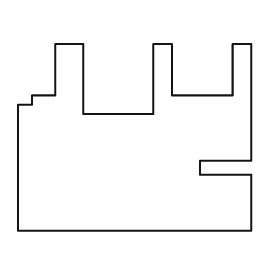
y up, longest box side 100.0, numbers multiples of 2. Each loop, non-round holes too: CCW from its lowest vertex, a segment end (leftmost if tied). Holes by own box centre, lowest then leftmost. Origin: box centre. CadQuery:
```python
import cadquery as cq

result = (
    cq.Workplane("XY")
    .moveTo(-50.0, -40.0)
    .lineTo(50.0, -40.0)
    .lineTo(50.0, -16.0)
    .lineTo(28.0, -16.0)
    .lineTo(28.0, -10.0)
    .lineTo(50.0, -10.0)
    .lineTo(50.0, 40.0)
    .lineTo(42.0, 40.0)
    .lineTo(42.0, 18.0)
    .lineTo(16.0, 18.0)
    .lineTo(16.0, 40.0)
    .lineTo(8.0, 40.0)
    .lineTo(8.0, 10.0)
    .lineTo(-22.0, 10.0)
    .lineTo(-22.0, 40.0)
    .lineTo(-34.0, 40.0)
    .lineTo(-34.0, 18.0)
    .lineTo(-44.0, 18.0)
    .lineTo(-44.0, 14.0)
    .lineTo(-50.0, 14.0)
    .close()
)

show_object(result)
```